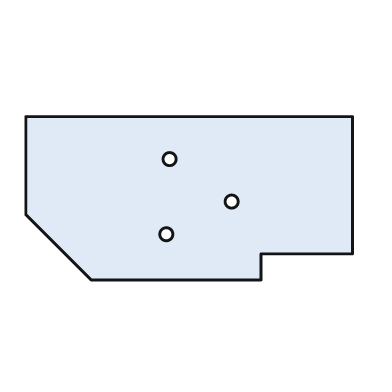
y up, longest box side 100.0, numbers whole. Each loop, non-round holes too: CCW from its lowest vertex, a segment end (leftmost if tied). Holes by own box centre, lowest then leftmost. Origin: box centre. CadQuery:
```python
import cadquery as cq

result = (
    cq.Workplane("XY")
    .moveTo(-30.0, -25.0)
    .lineTo(22.0, -25.0)
    .lineTo(22.0, -17.0)
    .lineTo(50.0, -17.0)
    .lineTo(50.0, 25.0)
    .lineTo(-50.0, 25.0)
    .lineTo(-50.0, -5.0)
    .close()
    .moveTo(-7.0, -11.0)
    .circle(2.0)
    .moveTo(13.0, -1.0)
    .circle(2.0)
    .moveTo(-6.0, 12.0)
    .circle(2.0)
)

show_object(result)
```